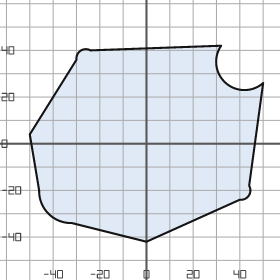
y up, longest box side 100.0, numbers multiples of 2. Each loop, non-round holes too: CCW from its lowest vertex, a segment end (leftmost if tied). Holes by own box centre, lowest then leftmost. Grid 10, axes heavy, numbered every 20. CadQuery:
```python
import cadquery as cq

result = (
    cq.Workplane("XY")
    .moveTo(0.0, -42.0)
    .lineTo(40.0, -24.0)
    .threePointArc((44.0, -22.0), (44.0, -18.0))
    .lineTo(50.0, 26.0)
    .threePointArc((34.0, 26.0), (32.0, 42.0))
    .lineTo(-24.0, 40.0)
    .threePointArc((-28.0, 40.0), (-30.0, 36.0))
    .lineTo(-50.0, 4.0)
    .lineTo(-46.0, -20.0)
    .threePointArc((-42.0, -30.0), (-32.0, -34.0))
    .close()
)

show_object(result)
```